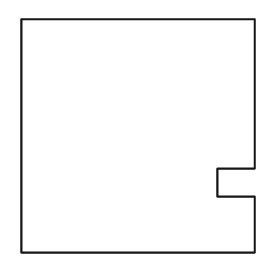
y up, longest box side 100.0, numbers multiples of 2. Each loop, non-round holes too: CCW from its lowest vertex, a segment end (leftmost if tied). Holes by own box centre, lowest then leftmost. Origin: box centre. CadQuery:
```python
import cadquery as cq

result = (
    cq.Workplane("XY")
    .moveTo(-50.0, -50.0)
    .lineTo(50.0, -50.0)
    .lineTo(50.0, -26.0)
    .lineTo(34.0, -26.0)
    .lineTo(34.0, -14.0)
    .lineTo(50.0, -14.0)
    .lineTo(50.0, 50.0)
    .lineTo(-50.0, 50.0)
    .close()
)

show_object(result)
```